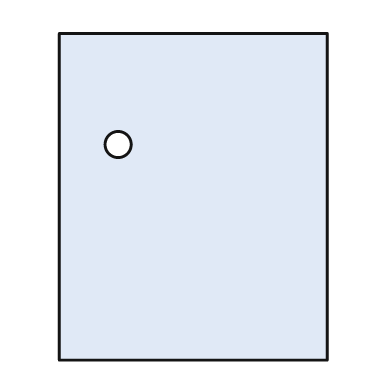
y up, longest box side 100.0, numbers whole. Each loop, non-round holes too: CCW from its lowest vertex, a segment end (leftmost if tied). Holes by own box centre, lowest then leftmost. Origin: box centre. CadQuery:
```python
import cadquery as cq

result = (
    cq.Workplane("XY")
    .moveTo(-41.0, -50.0)
    .lineTo(41.0, -50.0)
    .lineTo(41.0, 50.0)
    .lineTo(-41.0, 50.0)
    .close()
    .moveTo(-23.0, 16.0)
    .circle(4.0)
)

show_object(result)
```